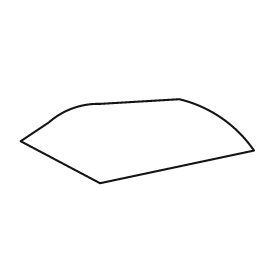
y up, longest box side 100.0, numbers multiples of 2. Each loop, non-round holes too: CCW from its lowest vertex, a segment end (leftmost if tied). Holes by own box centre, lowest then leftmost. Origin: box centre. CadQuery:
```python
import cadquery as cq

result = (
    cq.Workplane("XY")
    .moveTo(-16.0, -18.0)
    .lineTo(50.0, -4.0)
    .threePointArc((36.0, 10.0), (18.0, 18.0))
    .lineTo(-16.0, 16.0)
    .threePointArc((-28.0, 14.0), (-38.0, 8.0))
    .lineTo(-50.0, 0.0)
    .close()
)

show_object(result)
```